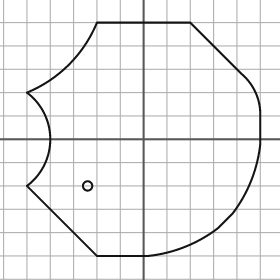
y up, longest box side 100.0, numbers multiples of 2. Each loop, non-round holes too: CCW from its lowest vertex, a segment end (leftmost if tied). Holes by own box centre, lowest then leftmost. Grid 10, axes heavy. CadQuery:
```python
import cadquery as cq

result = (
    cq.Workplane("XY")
    .moveTo(-20.0, -50.0)
    .lineTo(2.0, -50.0)
    .threePointArc((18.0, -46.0), (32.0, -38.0))
    .lineTo(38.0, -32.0)
    .threePointArc((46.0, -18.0), (50.0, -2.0))
    .lineTo(50.0, 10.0)
    .threePointArc((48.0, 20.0), (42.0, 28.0))
    .lineTo(20.0, 50.0)
    .lineTo(-20.0, 50.0)
    .threePointArc((-32.0, 32.0), (-50.0, 20.0))
    .threePointArc((-40.0, 0.0), (-50.0, -20.0))
    .close()
    .moveTo(-24.0, -20.0)
    .circle(2.0)
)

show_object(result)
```